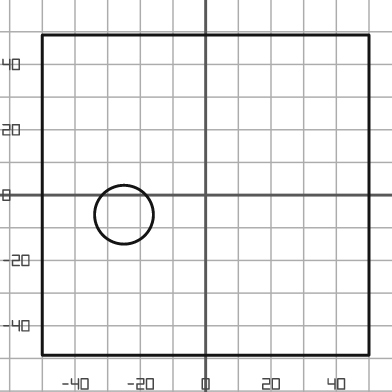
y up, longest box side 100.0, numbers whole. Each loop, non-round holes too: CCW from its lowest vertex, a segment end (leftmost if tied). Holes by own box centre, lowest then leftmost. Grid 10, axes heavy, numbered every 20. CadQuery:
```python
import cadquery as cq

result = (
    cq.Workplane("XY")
    .moveTo(-50.0, -49.0)
    .lineTo(50.0, -49.0)
    .lineTo(50.0, 49.0)
    .lineTo(-50.0, 49.0)
    .close()
    .moveTo(-25.0, -6.0)
    .circle(9.0)
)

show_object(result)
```